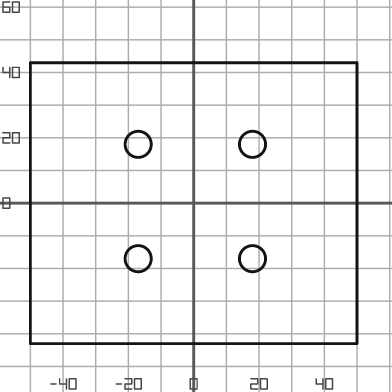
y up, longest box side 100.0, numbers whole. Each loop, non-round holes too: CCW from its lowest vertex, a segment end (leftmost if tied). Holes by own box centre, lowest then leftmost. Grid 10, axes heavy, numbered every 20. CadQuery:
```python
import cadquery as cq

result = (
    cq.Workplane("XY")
    .moveTo(-50.0, -43.0)
    .lineTo(50.0, -43.0)
    .lineTo(50.0, 43.0)
    .lineTo(-50.0, 43.0)
    .close()
    .moveTo(-17.0, -17.0)
    .circle(4.0)
    .moveTo(18.0, -17.0)
    .circle(4.0)
    .moveTo(-17.0, 18.0)
    .circle(4.0)
    .moveTo(18.0, 18.0)
    .circle(4.0)
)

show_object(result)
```